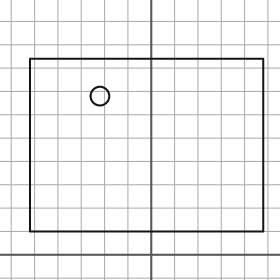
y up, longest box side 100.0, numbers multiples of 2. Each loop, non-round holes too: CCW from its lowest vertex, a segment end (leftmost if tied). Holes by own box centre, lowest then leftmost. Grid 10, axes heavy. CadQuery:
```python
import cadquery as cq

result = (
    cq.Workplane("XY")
    .moveTo(-52.0, 10.0)
    .lineTo(48.0, 10.0)
    .lineTo(48.0, 84.0)
    .lineTo(-52.0, 84.0)
    .close()
    .moveTo(-22.0, 68.0)
    .circle(4.0)
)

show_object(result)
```